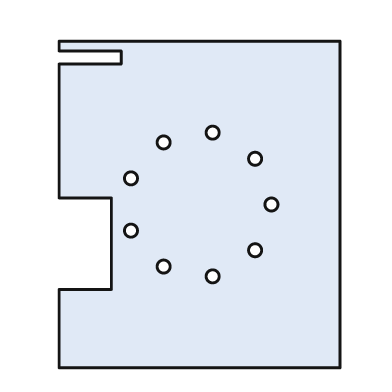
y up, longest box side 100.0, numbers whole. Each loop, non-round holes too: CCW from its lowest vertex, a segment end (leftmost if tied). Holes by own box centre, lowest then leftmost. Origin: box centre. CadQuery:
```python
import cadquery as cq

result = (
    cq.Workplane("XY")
    .moveTo(-43.0, -50.0)
    .lineTo(43.0, -50.0)
    .lineTo(43.0, 50.0)
    .lineTo(-43.0, 50.0)
    .lineTo(-43.0, 47.0)
    .lineTo(-24.0, 47.0)
    .lineTo(-24.0, 43.0)
    .lineTo(-43.0, 43.0)
    .lineTo(-43.0, 2.0)
    .lineTo(-27.0, 2.0)
    .lineTo(-27.0, -26.0)
    .lineTo(-43.0, -26.0)
    .close()
    .moveTo(4.0, -22.0)
    .circle(2.0)
    .moveTo(-11.0, -19.0)
    .circle(2.0)
    .moveTo(17.0, -14.0)
    .circle(2.0)
    .moveTo(-21.0, -8.0)
    .circle(2.0)
    .moveTo(22.0, 0.0)
    .circle(2.0)
    .moveTo(-21.0, 8.0)
    .circle(2.0)
    .moveTo(17.0, 14.0)
    .circle(2.0)
    .moveTo(-11.0, 19.0)
    .circle(2.0)
    .moveTo(4.0, 22.0)
    .circle(2.0)
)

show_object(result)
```